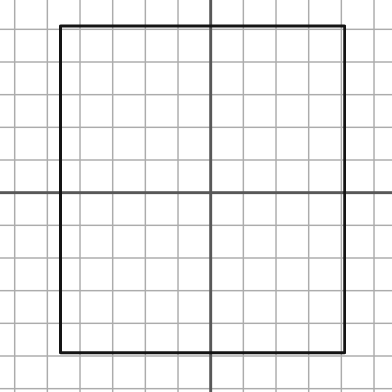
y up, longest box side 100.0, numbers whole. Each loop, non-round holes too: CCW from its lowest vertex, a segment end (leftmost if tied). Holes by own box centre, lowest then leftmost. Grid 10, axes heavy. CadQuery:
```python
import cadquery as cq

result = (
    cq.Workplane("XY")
    .moveTo(-46.0, -49.0)
    .lineTo(41.0, -49.0)
    .lineTo(41.0, 51.0)
    .lineTo(-46.0, 51.0)
    .close()
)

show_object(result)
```